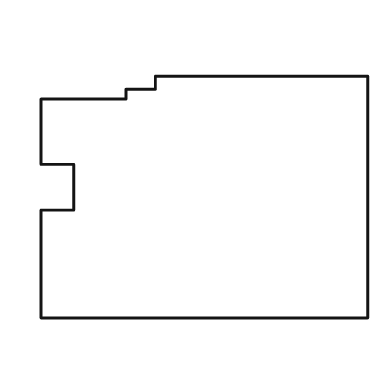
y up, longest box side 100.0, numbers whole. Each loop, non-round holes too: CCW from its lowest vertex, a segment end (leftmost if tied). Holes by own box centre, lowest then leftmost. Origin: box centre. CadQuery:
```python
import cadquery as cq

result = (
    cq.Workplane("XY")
    .moveTo(-50.0, -37.0)
    .lineTo(50.0, -37.0)
    .lineTo(50.0, 37.0)
    .lineTo(-15.0, 37.0)
    .lineTo(-15.0, 33.0)
    .lineTo(-24.0, 33.0)
    .lineTo(-24.0, 30.0)
    .lineTo(-50.0, 30.0)
    .lineTo(-50.0, 10.0)
    .lineTo(-40.0, 10.0)
    .lineTo(-40.0, -4.0)
    .lineTo(-50.0, -4.0)
    .close()
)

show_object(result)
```